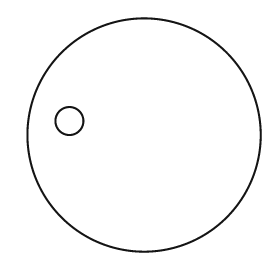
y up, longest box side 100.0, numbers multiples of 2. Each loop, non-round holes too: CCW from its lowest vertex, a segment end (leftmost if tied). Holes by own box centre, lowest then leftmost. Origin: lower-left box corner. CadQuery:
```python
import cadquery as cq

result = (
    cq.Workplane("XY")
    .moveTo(50.0, 50.0)
    .circle(50.0)
    .moveTo(18.0, 56.0)
    .circle(6.0)
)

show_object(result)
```